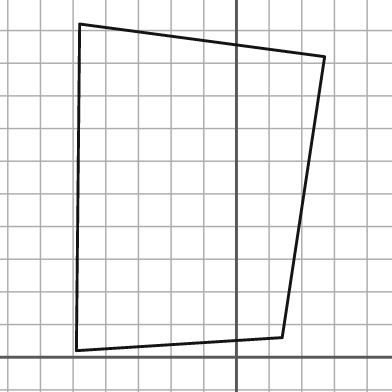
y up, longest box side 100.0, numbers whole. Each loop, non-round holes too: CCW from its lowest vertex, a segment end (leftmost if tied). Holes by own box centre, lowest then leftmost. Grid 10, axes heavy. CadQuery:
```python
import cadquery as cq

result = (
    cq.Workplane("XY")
    .moveTo(-49.0, 2.0)
    .lineTo(14.0, 6.0)
    .lineTo(27.0, 92.0)
    .lineTo(-48.0, 102.0)
    .close()
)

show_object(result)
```